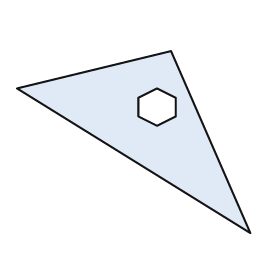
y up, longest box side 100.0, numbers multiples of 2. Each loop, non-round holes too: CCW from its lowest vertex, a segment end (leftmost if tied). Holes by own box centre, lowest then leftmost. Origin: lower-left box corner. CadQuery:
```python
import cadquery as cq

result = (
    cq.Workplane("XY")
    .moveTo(100.0, 0.0)
    .lineTo(66.0, 78.0)
    .lineTo(0.0, 62.0)
    .close()
    .moveTo(60.0, 46.0)
    .lineTo(68.0, 50.0)
    .lineTo(68.0, 58.0)
    .lineTo(60.0, 62.0)
    .lineTo(52.0, 58.0)
    .lineTo(52.0, 50.0)
    .close()
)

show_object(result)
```